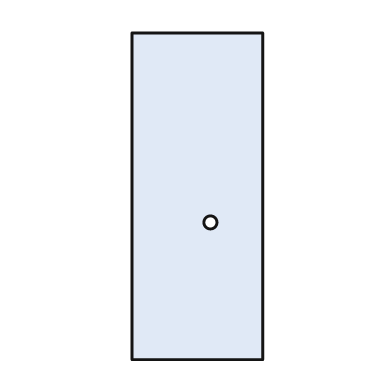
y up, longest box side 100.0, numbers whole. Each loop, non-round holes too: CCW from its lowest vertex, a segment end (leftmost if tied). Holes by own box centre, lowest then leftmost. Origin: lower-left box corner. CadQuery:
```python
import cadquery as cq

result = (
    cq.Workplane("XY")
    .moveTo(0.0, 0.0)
    .lineTo(40.0, 0.0)
    .lineTo(40.0, 100.0)
    .lineTo(0.0, 100.0)
    .close()
    .moveTo(24.0, 42.0)
    .circle(2.0)
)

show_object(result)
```